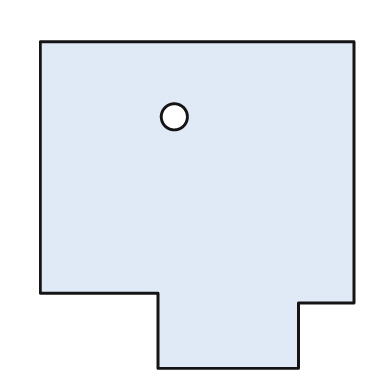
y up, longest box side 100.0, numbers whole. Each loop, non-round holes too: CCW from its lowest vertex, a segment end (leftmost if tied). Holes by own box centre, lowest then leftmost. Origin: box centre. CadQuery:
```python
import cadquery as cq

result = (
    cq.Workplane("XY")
    .moveTo(-12.0, -50.0)
    .lineTo(31.0, -50.0)
    .lineTo(31.0, -30.0)
    .lineTo(48.0, -30.0)
    .lineTo(48.0, 50.0)
    .lineTo(-48.0, 50.0)
    .lineTo(-48.0, -27.0)
    .lineTo(-12.0, -27.0)
    .close()
    .moveTo(-7.0, 27.0)
    .circle(4.0)
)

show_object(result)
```